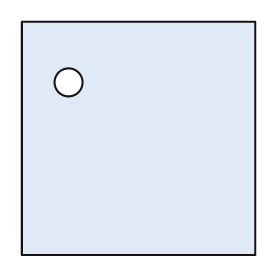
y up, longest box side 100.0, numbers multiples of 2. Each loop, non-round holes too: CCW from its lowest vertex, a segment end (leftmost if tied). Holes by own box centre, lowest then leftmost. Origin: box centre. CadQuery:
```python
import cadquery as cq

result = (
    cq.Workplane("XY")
    .moveTo(-50.0, -50.0)
    .lineTo(50.0, -50.0)
    .lineTo(50.0, 50.0)
    .lineTo(-50.0, 50.0)
    .close()
    .moveTo(-30.0, 24.0)
    .circle(6.0)
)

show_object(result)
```